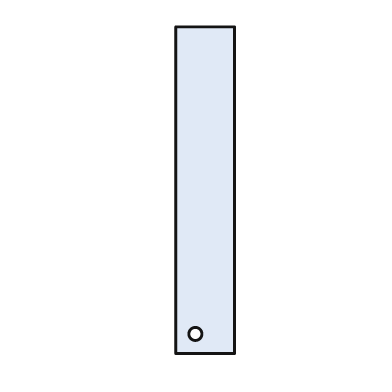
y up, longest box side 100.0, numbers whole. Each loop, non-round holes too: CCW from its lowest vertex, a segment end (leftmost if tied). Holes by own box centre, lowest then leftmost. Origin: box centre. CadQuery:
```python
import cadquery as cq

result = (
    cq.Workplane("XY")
    .moveTo(-9.0, -50.0)
    .lineTo(9.0, -50.0)
    .lineTo(9.0, 50.0)
    .lineTo(-9.0, 50.0)
    .close()
    .moveTo(-3.0, -44.0)
    .circle(2.0)
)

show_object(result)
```